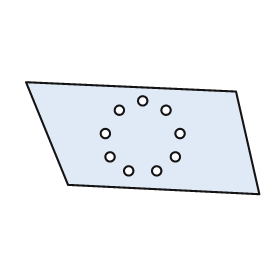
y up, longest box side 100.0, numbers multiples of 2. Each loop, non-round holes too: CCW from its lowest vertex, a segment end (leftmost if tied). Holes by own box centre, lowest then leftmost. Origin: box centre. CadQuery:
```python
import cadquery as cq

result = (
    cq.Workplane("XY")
    .moveTo(50.0, -24.0)
    .lineTo(40.0, 20.0)
    .lineTo(-50.0, 24.0)
    .lineTo(-32.0, -20.0)
    .close()
    .moveTo(-6.0, -14.0)
    .circle(2.0)
    .moveTo(6.0, -14.0)
    .circle(2.0)
    .moveTo(-14.0, -8.0)
    .circle(2.0)
    .moveTo(14.0, -8.0)
    .circle(2.0)
    .moveTo(-16.0, 2.0)
    .circle(2.0)
    .moveTo(16.0, 2.0)
    .circle(2.0)
    .moveTo(-10.0, 12.0)
    .circle(2.0)
    .moveTo(10.0, 12.0)
    .circle(2.0)
    .moveTo(0.0, 16.0)
    .circle(2.0)
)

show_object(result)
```